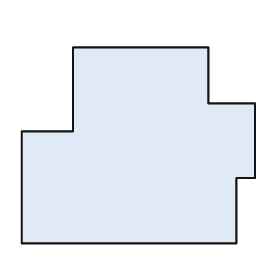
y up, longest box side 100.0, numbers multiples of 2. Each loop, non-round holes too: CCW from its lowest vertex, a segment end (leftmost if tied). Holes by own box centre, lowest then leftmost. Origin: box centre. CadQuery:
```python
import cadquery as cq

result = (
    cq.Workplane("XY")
    .moveTo(-50.0, -42.0)
    .lineTo(42.0, -42.0)
    .lineTo(42.0, -14.0)
    .lineTo(50.0, -14.0)
    .lineTo(50.0, 18.0)
    .lineTo(30.0, 18.0)
    .lineTo(30.0, 42.0)
    .lineTo(-28.0, 42.0)
    .lineTo(-28.0, 6.0)
    .lineTo(-50.0, 6.0)
    .close()
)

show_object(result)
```